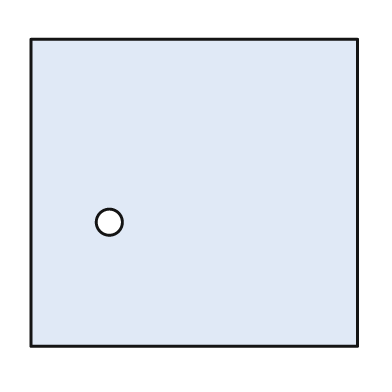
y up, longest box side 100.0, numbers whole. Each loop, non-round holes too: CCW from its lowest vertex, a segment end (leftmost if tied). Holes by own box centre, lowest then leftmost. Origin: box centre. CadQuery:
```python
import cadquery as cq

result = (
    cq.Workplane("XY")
    .moveTo(-50.0, -47.0)
    .lineTo(50.0, -47.0)
    .lineTo(50.0, 47.0)
    .lineTo(-50.0, 47.0)
    .close()
    .moveTo(-26.0, -9.0)
    .circle(4.0)
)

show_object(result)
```